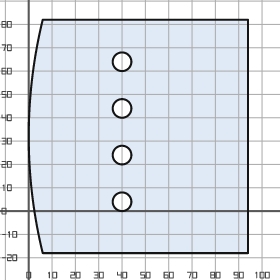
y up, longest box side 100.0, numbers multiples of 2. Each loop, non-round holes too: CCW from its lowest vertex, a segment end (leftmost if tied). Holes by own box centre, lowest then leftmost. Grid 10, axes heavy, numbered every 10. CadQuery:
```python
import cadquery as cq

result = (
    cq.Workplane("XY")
    .moveTo(6.0, -18.0)
    .lineTo(94.0, -18.0)
    .lineTo(94.0, 82.0)
    .lineTo(6.0, 82.0)
    .threePointArc((0.0, 32.0), (6.0, -18.0))
    .close()
    .moveTo(40.0, 4.0)
    .circle(4.0)
    .moveTo(40.0, 24.0)
    .circle(4.0)
    .moveTo(40.0, 44.0)
    .circle(4.0)
    .moveTo(40.0, 64.0)
    .circle(4.0)
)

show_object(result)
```